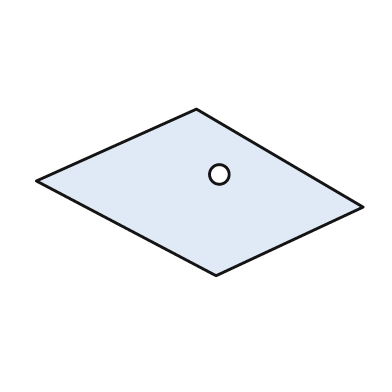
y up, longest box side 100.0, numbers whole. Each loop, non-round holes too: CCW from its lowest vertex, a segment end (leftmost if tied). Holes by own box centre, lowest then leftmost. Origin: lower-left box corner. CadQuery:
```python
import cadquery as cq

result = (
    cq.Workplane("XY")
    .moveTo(55.0, 0.0)
    .lineTo(100.0, 21.0)
    .lineTo(49.0, 51.0)
    .lineTo(0.0, 29.0)
    .close()
    .moveTo(56.0, 31.0)
    .circle(3.0)
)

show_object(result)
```